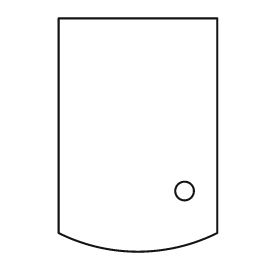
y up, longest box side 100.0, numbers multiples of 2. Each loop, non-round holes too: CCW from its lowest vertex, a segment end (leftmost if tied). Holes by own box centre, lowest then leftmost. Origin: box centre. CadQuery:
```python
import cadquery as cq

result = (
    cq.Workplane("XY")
    .moveTo(-34.0, -42.0)
    .threePointArc((0.0, -50.0), (34.0, -42.0))
    .lineTo(34.0, 50.0)
    .lineTo(-34.0, 50.0)
    .close()
    .moveTo(20.0, -24.0)
    .circle(4.0)
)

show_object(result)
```